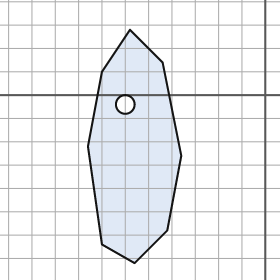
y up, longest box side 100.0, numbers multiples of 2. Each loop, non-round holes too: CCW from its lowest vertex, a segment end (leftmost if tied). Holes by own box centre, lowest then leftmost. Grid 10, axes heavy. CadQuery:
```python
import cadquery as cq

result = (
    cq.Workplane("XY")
    .moveTo(-56.0, -72.0)
    .lineTo(-42.0, -58.0)
    .lineTo(-36.0, -26.0)
    .lineTo(-44.0, 14.0)
    .lineTo(-58.0, 28.0)
    .lineTo(-70.0, 10.0)
    .lineTo(-76.0, -22.0)
    .lineTo(-70.0, -64.0)
    .close()
    .moveTo(-60.0, -4.0)
    .circle(4.0)
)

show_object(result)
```